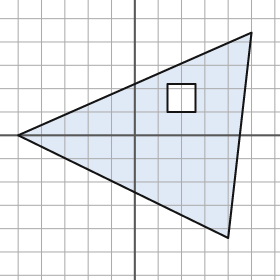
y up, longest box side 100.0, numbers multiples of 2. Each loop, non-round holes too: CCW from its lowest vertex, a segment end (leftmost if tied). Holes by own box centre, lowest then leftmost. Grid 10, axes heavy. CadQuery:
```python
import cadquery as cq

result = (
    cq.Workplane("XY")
    .moveTo(40.0, -44.0)
    .lineTo(50.0, 44.0)
    .lineTo(-50.0, 0.0)
    .close()
    .moveTo(14.0, 10.0)
    .lineTo(26.0, 10.0)
    .lineTo(26.0, 22.0)
    .lineTo(14.0, 22.0)
    .close()
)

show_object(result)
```